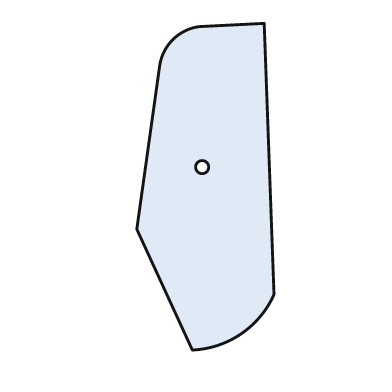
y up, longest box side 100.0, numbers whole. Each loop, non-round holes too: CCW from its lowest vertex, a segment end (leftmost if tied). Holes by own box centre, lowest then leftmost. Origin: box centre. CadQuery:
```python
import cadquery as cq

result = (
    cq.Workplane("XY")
    .moveTo(-4.0, -50.0)
    .threePointArc((11.0, -45.0), (21.0, -33.0))
    .lineTo(18.0, 50.0)
    .lineTo(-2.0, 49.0)
    .threePointArc((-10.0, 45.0), (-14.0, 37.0))
    .lineTo(-21.0, -13.0)
    .close()
    .moveTo(-1.0, 6.0)
    .circle(2.0)
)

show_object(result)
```